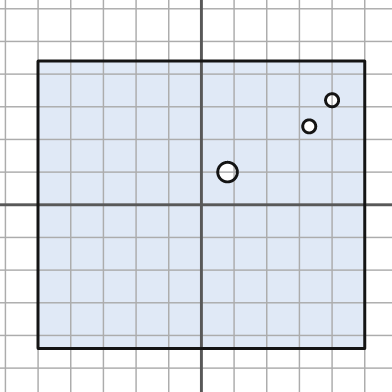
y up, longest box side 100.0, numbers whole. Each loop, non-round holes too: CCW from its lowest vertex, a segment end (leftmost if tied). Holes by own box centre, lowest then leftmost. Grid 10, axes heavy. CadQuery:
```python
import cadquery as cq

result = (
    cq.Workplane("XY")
    .moveTo(-50.0, -44.0)
    .lineTo(50.0, -44.0)
    .lineTo(50.0, 44.0)
    .lineTo(-50.0, 44.0)
    .close()
    .moveTo(8.0, 10.0)
    .circle(3.0)
    .moveTo(33.0, 24.0)
    .circle(2.0)
    .moveTo(40.0, 32.0)
    .circle(2.0)
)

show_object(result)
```